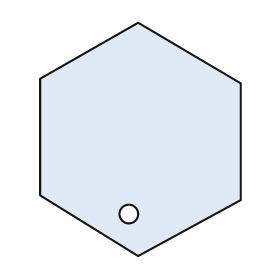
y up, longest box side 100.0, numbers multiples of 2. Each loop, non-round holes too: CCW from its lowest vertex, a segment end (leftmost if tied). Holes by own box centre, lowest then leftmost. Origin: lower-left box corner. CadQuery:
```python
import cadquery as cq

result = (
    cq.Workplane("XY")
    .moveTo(42.0, 0.0)
    .lineTo(86.0, 24.0)
    .lineTo(86.0, 74.0)
    .lineTo(42.0, 100.0)
    .lineTo(0.0, 76.0)
    .lineTo(0.0, 26.0)
    .close()
    .moveTo(38.0, 18.0)
    .circle(4.0)
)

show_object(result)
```